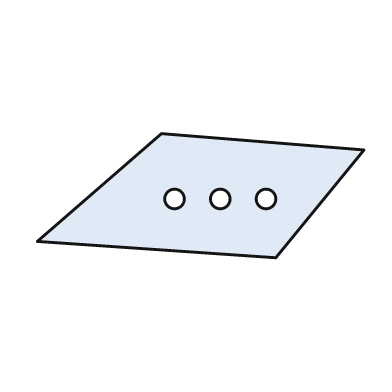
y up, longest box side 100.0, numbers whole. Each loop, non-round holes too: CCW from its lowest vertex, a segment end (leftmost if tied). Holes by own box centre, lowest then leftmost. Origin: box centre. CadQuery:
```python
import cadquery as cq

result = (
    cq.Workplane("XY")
    .moveTo(23.0, -19.0)
    .lineTo(50.0, 14.0)
    .lineTo(-12.0, 19.0)
    .lineTo(-50.0, -14.0)
    .close()
    .moveTo(-8.0, -1.0)
    .circle(3.0)
    .moveTo(6.0, -1.0)
    .circle(3.0)
    .moveTo(20.0, -1.0)
    .circle(3.0)
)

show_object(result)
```